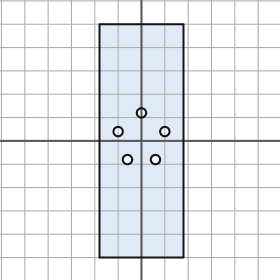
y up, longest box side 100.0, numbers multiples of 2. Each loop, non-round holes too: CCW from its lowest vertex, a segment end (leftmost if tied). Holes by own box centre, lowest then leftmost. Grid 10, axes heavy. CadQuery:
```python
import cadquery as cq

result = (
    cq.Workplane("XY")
    .moveTo(-18.0, -50.0)
    .lineTo(18.0, -50.0)
    .lineTo(18.0, 50.0)
    .lineTo(-18.0, 50.0)
    .close()
    .moveTo(-6.0, -8.0)
    .circle(2.0)
    .moveTo(6.0, -8.0)
    .circle(2.0)
    .moveTo(-10.0, 4.0)
    .circle(2.0)
    .moveTo(10.0, 4.0)
    .circle(2.0)
    .moveTo(0.0, 12.0)
    .circle(2.0)
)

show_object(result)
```